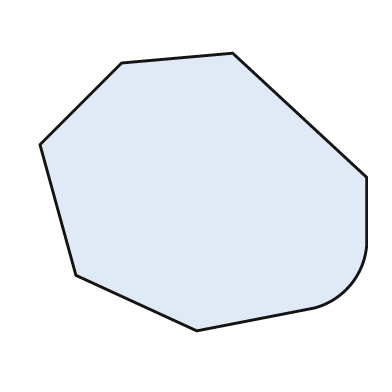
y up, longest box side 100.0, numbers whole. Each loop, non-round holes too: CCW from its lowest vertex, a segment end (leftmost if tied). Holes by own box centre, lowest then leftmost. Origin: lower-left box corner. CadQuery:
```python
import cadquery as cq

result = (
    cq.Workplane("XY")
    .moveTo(48.0, 0.0)
    .lineTo(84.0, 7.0)
    .threePointArc((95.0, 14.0), (100.0, 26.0))
    .lineTo(100.0, 47.0)
    .lineTo(59.0, 85.0)
    .lineTo(25.0, 82.0)
    .lineTo(0.0, 57.0)
    .lineTo(11.0, 17.0)
    .close()
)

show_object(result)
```